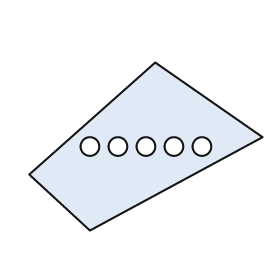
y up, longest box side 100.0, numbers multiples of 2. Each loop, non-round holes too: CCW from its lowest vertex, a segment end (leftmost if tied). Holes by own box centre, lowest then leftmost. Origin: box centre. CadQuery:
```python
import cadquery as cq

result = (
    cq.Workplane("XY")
    .moveTo(-24.0, -36.0)
    .lineTo(50.0, 4.0)
    .lineTo(4.0, 36.0)
    .lineTo(-50.0, -12.0)
    .close()
    .moveTo(-24.0, 0.0)
    .circle(4.0)
    .moveTo(-12.0, 0.0)
    .circle(4.0)
    .moveTo(0.0, 0.0)
    .circle(4.0)
    .moveTo(12.0, 0.0)
    .circle(4.0)
    .moveTo(24.0, 0.0)
    .circle(4.0)
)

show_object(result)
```